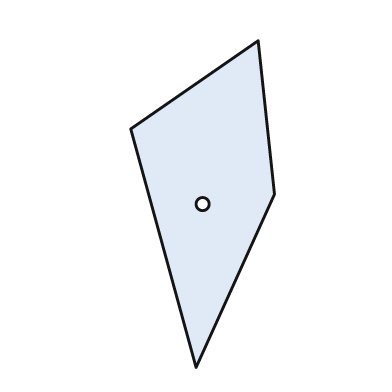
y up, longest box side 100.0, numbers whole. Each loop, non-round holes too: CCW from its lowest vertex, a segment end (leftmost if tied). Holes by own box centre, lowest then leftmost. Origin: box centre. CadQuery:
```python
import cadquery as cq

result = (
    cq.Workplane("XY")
    .moveTo(-2.0, -50.0)
    .lineTo(22.0, 3.0)
    .lineTo(17.0, 50.0)
    .lineTo(-22.0, 23.0)
    .close()
    .moveTo(0.0, 0.0)
    .circle(2.0)
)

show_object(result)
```